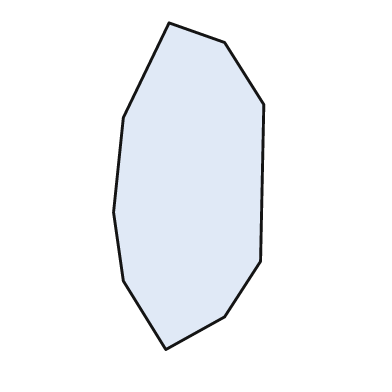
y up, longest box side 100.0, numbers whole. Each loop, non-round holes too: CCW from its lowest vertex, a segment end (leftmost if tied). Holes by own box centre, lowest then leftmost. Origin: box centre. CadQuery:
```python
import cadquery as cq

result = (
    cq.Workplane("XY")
    .moveTo(-7.0, -50.0)
    .lineTo(11.0, -40.0)
    .lineTo(22.0, -23.0)
    .lineTo(23.0, 25.0)
    .lineTo(11.0, 44.0)
    .lineTo(-6.0, 50.0)
    .lineTo(-20.0, 21.0)
    .lineTo(-23.0, -8.0)
    .lineTo(-20.0, -29.0)
    .close()
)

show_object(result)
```